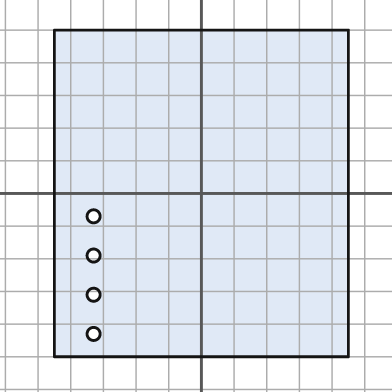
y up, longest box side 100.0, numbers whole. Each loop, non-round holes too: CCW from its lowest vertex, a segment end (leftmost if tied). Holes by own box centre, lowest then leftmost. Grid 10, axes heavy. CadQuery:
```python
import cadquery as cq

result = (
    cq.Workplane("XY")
    .moveTo(-45.0, -50.0)
    .lineTo(45.0, -50.0)
    .lineTo(45.0, 50.0)
    .lineTo(-45.0, 50.0)
    .close()
    .moveTo(-33.0, -43.0)
    .circle(2.0)
    .moveTo(-33.0, -31.0)
    .circle(2.0)
    .moveTo(-33.0, -19.0)
    .circle(2.0)
    .moveTo(-33.0, -7.0)
    .circle(2.0)
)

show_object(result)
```